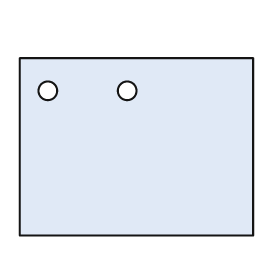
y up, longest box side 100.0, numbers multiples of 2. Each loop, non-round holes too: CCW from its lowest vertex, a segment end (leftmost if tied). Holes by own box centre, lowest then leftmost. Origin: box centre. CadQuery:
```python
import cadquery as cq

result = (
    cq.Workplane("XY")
    .moveTo(-50.0, -38.0)
    .lineTo(50.0, -38.0)
    .lineTo(50.0, 38.0)
    .lineTo(-50.0, 38.0)
    .close()
    .moveTo(-38.0, 24.0)
    .circle(4.0)
    .moveTo(-4.0, 24.0)
    .circle(4.0)
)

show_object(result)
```